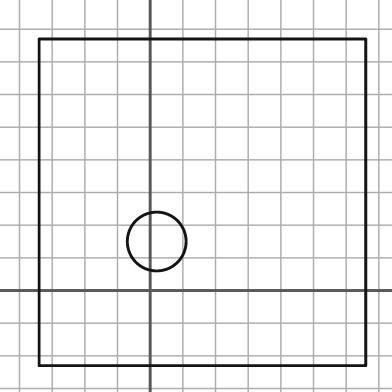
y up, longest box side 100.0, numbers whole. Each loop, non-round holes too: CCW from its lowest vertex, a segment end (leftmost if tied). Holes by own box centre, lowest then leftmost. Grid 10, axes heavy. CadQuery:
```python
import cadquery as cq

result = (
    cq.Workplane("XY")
    .moveTo(-34.0, -23.0)
    .lineTo(66.0, -23.0)
    .lineTo(66.0, 77.0)
    .lineTo(-34.0, 77.0)
    .close()
    .moveTo(2.0, 15.0)
    .circle(9.0)
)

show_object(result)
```